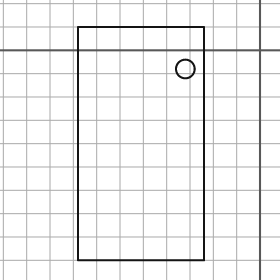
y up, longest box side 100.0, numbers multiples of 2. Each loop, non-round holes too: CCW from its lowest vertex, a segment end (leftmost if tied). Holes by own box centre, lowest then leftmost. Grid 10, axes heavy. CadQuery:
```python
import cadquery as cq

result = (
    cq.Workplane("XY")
    .moveTo(-78.0, -90.0)
    .lineTo(-24.0, -90.0)
    .lineTo(-24.0, 10.0)
    .lineTo(-78.0, 10.0)
    .close()
    .moveTo(-32.0, -8.0)
    .circle(4.0)
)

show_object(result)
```